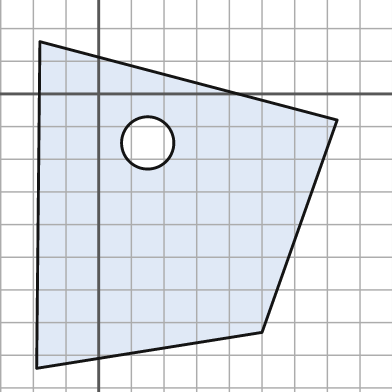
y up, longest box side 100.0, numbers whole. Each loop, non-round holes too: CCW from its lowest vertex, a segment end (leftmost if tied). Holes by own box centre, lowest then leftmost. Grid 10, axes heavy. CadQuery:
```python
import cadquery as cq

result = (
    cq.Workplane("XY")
    .moveTo(-19.0, -84.0)
    .lineTo(50.0, -73.0)
    .lineTo(73.0, -8.0)
    .lineTo(-18.0, 16.0)
    .close()
    .moveTo(15.0, -15.0)
    .circle(8.0)
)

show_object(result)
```